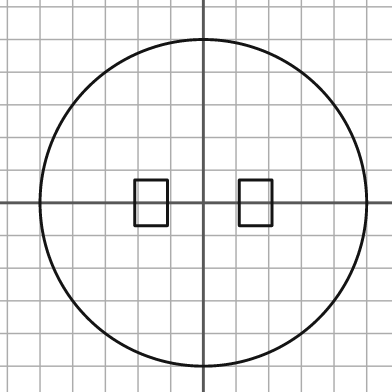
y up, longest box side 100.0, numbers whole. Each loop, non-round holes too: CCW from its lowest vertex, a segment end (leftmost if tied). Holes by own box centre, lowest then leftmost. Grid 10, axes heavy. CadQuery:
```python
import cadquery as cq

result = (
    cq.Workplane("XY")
    .moveTo(0.0, 0.0)
    .circle(50.0)
    .moveTo(-21.0, -7.0)
    .lineTo(-11.0, -7.0)
    .lineTo(-11.0, 7.0)
    .lineTo(-21.0, 7.0)
    .close()
    .moveTo(11.0, -7.0)
    .lineTo(21.0, -7.0)
    .lineTo(21.0, 7.0)
    .lineTo(11.0, 7.0)
    .close()
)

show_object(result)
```